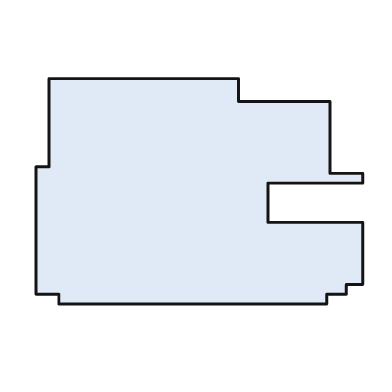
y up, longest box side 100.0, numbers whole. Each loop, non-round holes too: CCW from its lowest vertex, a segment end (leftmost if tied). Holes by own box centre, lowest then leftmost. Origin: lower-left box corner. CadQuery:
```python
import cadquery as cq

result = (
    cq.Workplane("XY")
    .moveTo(7.0, 0.0)
    .lineTo(89.0, 0.0)
    .lineTo(89.0, 3.0)
    .lineTo(95.0, 3.0)
    .lineTo(95.0, 6.0)
    .lineTo(100.0, 6.0)
    .lineTo(100.0, 25.0)
    .lineTo(71.0, 25.0)
    .lineTo(71.0, 37.0)
    .lineTo(100.0, 37.0)
    .lineTo(100.0, 40.0)
    .lineTo(90.0, 40.0)
    .lineTo(90.0, 62.0)
    .lineTo(62.0, 62.0)
    .lineTo(62.0, 69.0)
    .lineTo(4.0, 69.0)
    .lineTo(4.0, 42.0)
    .lineTo(0.0, 42.0)
    .lineTo(0.0, 3.0)
    .lineTo(7.0, 3.0)
    .close()
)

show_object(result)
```